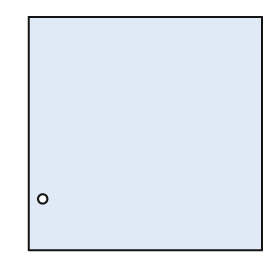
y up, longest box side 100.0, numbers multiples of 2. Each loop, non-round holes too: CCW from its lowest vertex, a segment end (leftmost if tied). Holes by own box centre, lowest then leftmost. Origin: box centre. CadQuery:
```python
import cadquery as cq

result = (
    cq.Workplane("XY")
    .moveTo(-50.0, -50.0)
    .lineTo(50.0, -50.0)
    .lineTo(50.0, 50.0)
    .lineTo(-50.0, 50.0)
    .close()
    .moveTo(-44.0, -28.0)
    .circle(2.0)
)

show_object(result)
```